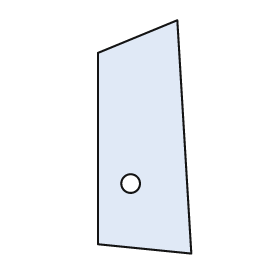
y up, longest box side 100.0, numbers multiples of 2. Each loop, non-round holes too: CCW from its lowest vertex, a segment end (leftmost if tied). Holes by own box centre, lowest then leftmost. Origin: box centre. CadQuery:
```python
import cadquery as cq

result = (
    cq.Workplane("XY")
    .moveTo(20.0, -50.0)
    .lineTo(14.0, 50.0)
    .lineTo(-20.0, 36.0)
    .lineTo(-20.0, -46.0)
    .close()
    .moveTo(-6.0, -20.0)
    .circle(4.0)
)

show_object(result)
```